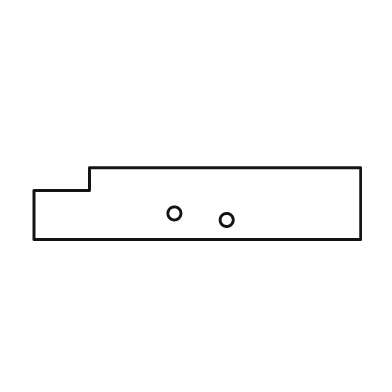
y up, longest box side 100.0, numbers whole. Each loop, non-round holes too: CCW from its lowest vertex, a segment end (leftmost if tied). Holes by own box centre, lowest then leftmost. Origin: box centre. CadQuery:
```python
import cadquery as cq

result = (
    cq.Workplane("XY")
    .moveTo(-50.0, -11.0)
    .lineTo(50.0, -11.0)
    .lineTo(50.0, 11.0)
    .lineTo(-33.0, 11.0)
    .lineTo(-33.0, 4.0)
    .lineTo(-50.0, 4.0)
    .close()
    .moveTo(9.0, -5.0)
    .circle(2.0)
    .moveTo(-7.0, -3.0)
    .circle(2.0)
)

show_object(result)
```